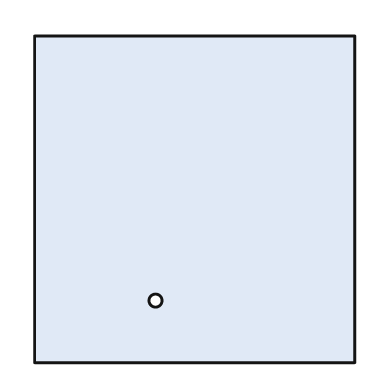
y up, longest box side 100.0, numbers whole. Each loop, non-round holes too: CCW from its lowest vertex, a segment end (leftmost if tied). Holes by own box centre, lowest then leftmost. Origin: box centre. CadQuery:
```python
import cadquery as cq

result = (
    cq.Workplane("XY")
    .moveTo(-49.0, -50.0)
    .lineTo(49.0, -50.0)
    .lineTo(49.0, 50.0)
    .lineTo(-49.0, 50.0)
    .close()
    .moveTo(-12.0, -31.0)
    .circle(2.0)
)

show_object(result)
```